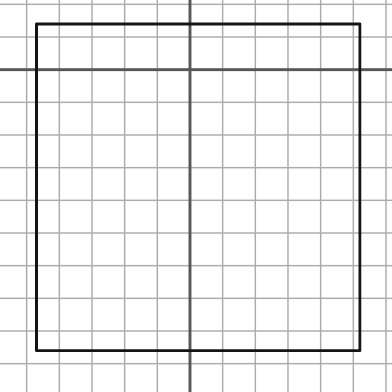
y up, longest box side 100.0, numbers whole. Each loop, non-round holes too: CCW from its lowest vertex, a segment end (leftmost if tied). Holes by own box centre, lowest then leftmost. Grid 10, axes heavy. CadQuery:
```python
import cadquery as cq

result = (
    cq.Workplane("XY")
    .moveTo(-47.0, -86.0)
    .lineTo(52.0, -86.0)
    .lineTo(52.0, 14.0)
    .lineTo(-47.0, 14.0)
    .close()
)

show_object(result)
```